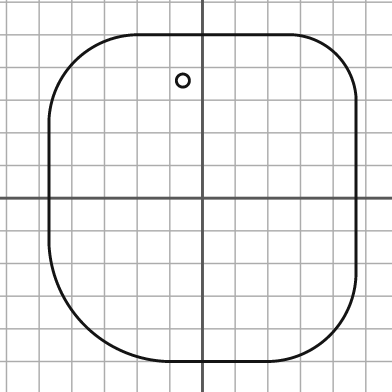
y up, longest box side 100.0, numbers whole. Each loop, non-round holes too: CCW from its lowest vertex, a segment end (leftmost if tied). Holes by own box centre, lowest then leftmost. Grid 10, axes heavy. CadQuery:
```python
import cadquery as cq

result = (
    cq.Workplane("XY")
    .moveTo(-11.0, -50.0)
    .lineTo(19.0, -50.0)
    .threePointArc((39.0, -42.0), (47.0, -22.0))
    .lineTo(47.0, 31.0)
    .threePointArc((41.0, 44.0), (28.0, 50.0))
    .lineTo(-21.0, 50.0)
    .threePointArc((-39.0, 42.0), (-47.0, 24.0))
    .lineTo(-47.0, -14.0)
    .threePointArc((-36.0, -39.0), (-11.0, -50.0))
    .close()
    .moveTo(-6.0, 36.0)
    .circle(2.0)
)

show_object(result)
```